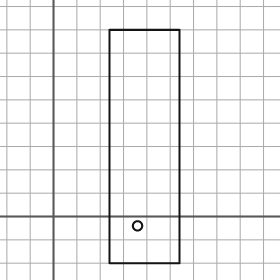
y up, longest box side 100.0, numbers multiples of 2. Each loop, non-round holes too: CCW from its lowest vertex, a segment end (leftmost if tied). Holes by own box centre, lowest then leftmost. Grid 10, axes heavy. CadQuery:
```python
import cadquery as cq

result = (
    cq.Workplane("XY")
    .moveTo(24.0, -20.0)
    .lineTo(54.0, -20.0)
    .lineTo(54.0, 80.0)
    .lineTo(24.0, 80.0)
    .close()
    .moveTo(36.0, -4.0)
    .circle(2.0)
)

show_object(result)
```